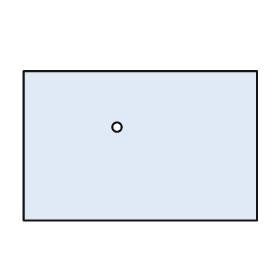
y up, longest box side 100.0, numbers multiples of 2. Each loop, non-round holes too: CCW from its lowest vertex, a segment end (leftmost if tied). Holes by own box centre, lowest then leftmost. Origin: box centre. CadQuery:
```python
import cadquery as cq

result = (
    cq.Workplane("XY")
    .moveTo(-50.0, -32.0)
    .lineTo(50.0, -32.0)
    .lineTo(50.0, 32.0)
    .lineTo(-50.0, 32.0)
    .close()
    .moveTo(-10.0, 8.0)
    .circle(2.0)
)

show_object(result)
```